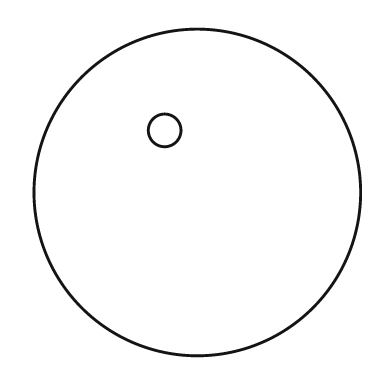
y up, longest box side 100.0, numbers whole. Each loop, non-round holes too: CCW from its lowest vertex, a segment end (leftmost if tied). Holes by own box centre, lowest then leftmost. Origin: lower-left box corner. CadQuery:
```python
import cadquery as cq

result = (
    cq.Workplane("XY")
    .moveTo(50.0, 50.0)
    .circle(50.0)
    .moveTo(40.0, 69.0)
    .circle(5.0)
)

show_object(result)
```